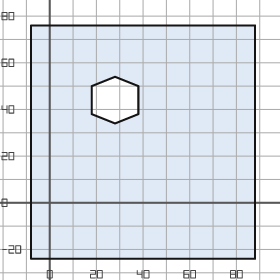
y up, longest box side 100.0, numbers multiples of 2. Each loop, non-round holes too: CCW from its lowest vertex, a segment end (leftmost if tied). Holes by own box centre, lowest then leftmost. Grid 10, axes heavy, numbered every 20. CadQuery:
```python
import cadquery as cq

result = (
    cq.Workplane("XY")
    .moveTo(-8.0, -24.0)
    .lineTo(88.0, -24.0)
    .lineTo(88.0, 76.0)
    .lineTo(-8.0, 76.0)
    .close()
    .moveTo(28.0, 34.0)
    .lineTo(38.0, 38.0)
    .lineTo(38.0, 50.0)
    .lineTo(28.0, 54.0)
    .lineTo(18.0, 50.0)
    .lineTo(18.0, 38.0)
    .close()
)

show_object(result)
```